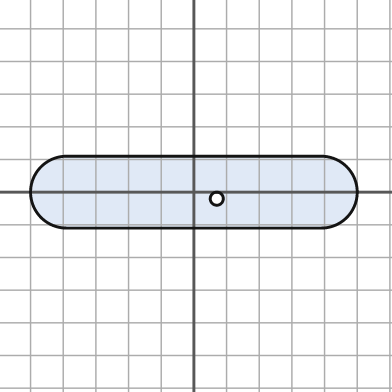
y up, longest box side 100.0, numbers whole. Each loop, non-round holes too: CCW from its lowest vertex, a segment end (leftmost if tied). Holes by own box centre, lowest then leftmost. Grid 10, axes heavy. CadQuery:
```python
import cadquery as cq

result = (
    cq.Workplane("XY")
    .moveTo(-39.0, -11.0)
    .lineTo(39.0, -11.0)
    .threePointArc((50.0, 0.0), (39.0, 11.0))
    .lineTo(-39.0, 11.0)
    .threePointArc((-50.0, 0.0), (-39.0, -11.0))
    .close()
    .moveTo(7.0, -2.0)
    .circle(2.0)
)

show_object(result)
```